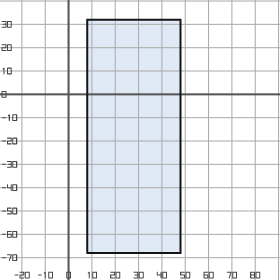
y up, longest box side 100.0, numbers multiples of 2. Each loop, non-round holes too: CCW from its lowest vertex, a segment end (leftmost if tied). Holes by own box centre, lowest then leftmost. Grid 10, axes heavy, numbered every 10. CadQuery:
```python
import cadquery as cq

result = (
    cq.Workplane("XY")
    .moveTo(8.0, -68.0)
    .lineTo(48.0, -68.0)
    .lineTo(48.0, 32.0)
    .lineTo(8.0, 32.0)
    .close()
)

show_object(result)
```